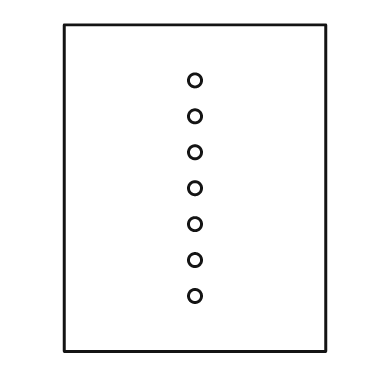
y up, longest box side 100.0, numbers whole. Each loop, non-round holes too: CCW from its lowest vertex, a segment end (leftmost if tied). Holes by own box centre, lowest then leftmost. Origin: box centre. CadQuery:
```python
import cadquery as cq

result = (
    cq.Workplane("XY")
    .moveTo(-40.0, -50.0)
    .lineTo(40.0, -50.0)
    .lineTo(40.0, 50.0)
    .lineTo(-40.0, 50.0)
    .close()
    .moveTo(0.0, -33.0)
    .circle(2.0)
    .moveTo(0.0, -22.0)
    .circle(2.0)
    .moveTo(0.0, -11.0)
    .circle(2.0)
    .moveTo(0.0, 0.0)
    .circle(2.0)
    .moveTo(0.0, 11.0)
    .circle(2.0)
    .moveTo(0.0, 22.0)
    .circle(2.0)
    .moveTo(0.0, 33.0)
    .circle(2.0)
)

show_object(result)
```